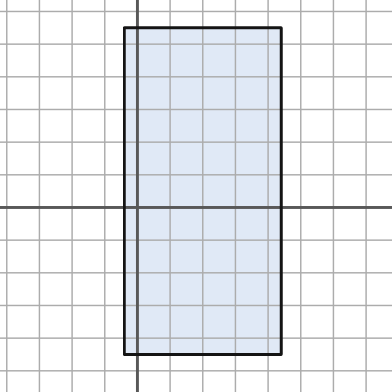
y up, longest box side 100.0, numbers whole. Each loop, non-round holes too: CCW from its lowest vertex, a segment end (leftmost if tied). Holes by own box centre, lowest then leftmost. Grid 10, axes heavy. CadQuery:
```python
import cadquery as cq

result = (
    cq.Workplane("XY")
    .moveTo(-4.0, -45.0)
    .lineTo(44.0, -45.0)
    .lineTo(44.0, 55.0)
    .lineTo(-4.0, 55.0)
    .close()
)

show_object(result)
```